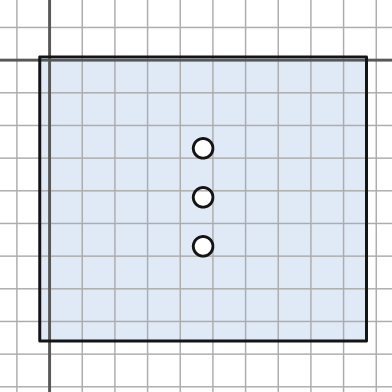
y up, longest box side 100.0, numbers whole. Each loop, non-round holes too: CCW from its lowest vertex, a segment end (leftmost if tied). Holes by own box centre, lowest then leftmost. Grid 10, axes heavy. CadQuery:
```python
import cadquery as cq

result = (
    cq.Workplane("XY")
    .moveTo(-3.0, -86.0)
    .lineTo(97.0, -86.0)
    .lineTo(97.0, 1.0)
    .lineTo(-3.0, 1.0)
    .close()
    .moveTo(47.0, -57.0)
    .circle(3.0)
    .moveTo(47.0, -42.0)
    .circle(3.0)
    .moveTo(47.0, -27.0)
    .circle(3.0)
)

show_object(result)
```